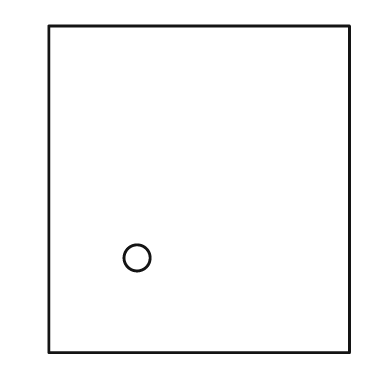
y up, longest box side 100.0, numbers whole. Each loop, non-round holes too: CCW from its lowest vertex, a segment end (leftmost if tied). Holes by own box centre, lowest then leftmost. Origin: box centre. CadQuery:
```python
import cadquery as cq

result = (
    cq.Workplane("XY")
    .moveTo(-46.0, -50.0)
    .lineTo(46.0, -50.0)
    .lineTo(46.0, 50.0)
    .lineTo(-46.0, 50.0)
    .close()
    .moveTo(-19.0, -21.0)
    .circle(4.0)
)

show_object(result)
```